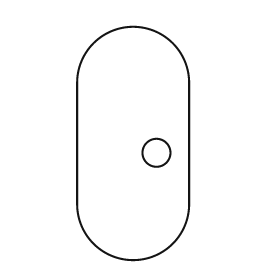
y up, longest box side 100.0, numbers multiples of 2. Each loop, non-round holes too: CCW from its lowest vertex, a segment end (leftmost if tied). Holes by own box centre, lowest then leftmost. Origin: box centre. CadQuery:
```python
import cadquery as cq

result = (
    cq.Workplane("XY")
    .moveTo(-24.0, -26.0)
    .threePointArc((0.0, -50.0), (24.0, -26.0))
    .lineTo(24.0, 26.0)
    .threePointArc((0.0, 50.0), (-24.0, 26.0))
    .close()
    .moveTo(10.0, -4.0)
    .circle(6.0)
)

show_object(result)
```